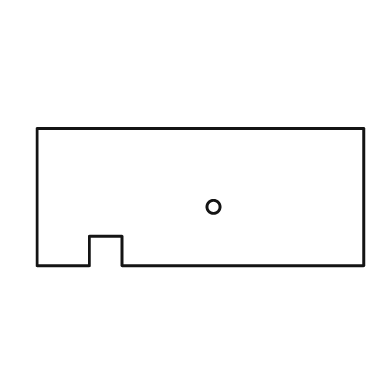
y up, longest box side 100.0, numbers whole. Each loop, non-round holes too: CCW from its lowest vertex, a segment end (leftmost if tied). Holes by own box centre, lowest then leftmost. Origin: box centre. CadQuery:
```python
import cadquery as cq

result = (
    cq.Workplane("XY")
    .moveTo(-50.0, -21.0)
    .lineTo(-34.0, -21.0)
    .lineTo(-34.0, -12.0)
    .lineTo(-24.0, -12.0)
    .lineTo(-24.0, -21.0)
    .lineTo(50.0, -21.0)
    .lineTo(50.0, 21.0)
    .lineTo(-50.0, 21.0)
    .close()
    .moveTo(4.0, -3.0)
    .circle(2.0)
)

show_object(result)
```